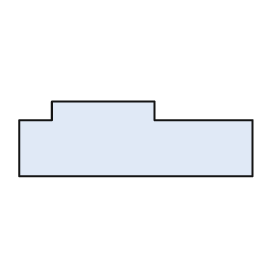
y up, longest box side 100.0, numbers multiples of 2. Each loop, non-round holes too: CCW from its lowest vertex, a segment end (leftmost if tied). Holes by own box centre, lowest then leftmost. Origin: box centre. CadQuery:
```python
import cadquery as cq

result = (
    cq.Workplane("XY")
    .moveTo(-50.0, -16.0)
    .lineTo(50.0, -16.0)
    .lineTo(50.0, 8.0)
    .lineTo(8.0, 8.0)
    .lineTo(8.0, 16.0)
    .lineTo(-36.0, 16.0)
    .lineTo(-36.0, 8.0)
    .lineTo(-50.0, 8.0)
    .close()
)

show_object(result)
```